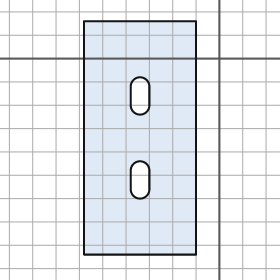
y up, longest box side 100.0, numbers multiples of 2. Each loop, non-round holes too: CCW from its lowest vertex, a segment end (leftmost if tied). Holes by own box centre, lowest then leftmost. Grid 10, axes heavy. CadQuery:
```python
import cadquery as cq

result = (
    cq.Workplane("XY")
    .moveTo(-58.0, -84.0)
    .lineTo(-10.0, -84.0)
    .lineTo(-10.0, 16.0)
    .lineTo(-58.0, 16.0)
    .close()
    .moveTo(-38.0, -56.0)
    .threePointArc((-34.0, -60.0), (-30.0, -56.0))
    .lineTo(-30.0, -48.0)
    .threePointArc((-34.0, -44.0), (-38.0, -48.0))
    .close()
    .moveTo(-38.0, -20.0)
    .threePointArc((-34.0, -24.0), (-30.0, -20.0))
    .lineTo(-30.0, -12.0)
    .threePointArc((-34.0, -8.0), (-38.0, -12.0))
    .close()
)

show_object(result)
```